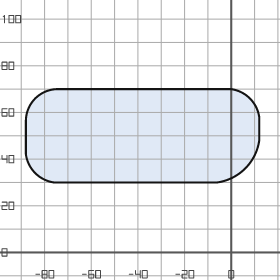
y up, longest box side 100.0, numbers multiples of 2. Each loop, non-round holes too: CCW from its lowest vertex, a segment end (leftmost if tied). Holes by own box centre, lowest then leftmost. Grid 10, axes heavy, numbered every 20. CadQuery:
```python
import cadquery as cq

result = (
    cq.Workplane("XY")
    .moveTo(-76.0, 30.0)
    .lineTo(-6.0, 30.0)
    .threePointArc((6.0, 36.0), (12.0, 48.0))
    .lineTo(12.0, 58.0)
    .threePointArc((8.0, 66.0), (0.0, 70.0))
    .lineTo(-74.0, 70.0)
    .threePointArc((-84.0, 66.0), (-88.0, 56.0))
    .lineTo(-88.0, 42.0)
    .threePointArc((-84.0, 34.0), (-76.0, 30.0))
    .close()
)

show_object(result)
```